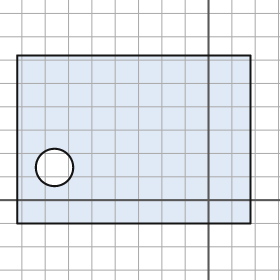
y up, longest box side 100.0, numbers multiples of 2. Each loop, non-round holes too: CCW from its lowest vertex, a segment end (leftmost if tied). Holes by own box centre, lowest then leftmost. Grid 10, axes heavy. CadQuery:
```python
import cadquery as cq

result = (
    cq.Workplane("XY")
    .moveTo(-82.0, -10.0)
    .lineTo(18.0, -10.0)
    .lineTo(18.0, 62.0)
    .lineTo(-82.0, 62.0)
    .close()
    .moveTo(-66.0, 14.0)
    .circle(8.0)
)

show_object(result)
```